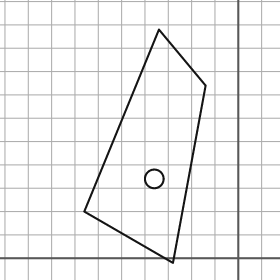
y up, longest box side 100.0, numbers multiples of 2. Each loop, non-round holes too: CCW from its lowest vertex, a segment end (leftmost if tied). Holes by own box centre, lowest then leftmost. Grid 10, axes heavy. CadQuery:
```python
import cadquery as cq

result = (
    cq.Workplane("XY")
    .moveTo(-28.0, -2.0)
    .lineTo(-14.0, 74.0)
    .lineTo(-34.0, 98.0)
    .lineTo(-66.0, 20.0)
    .close()
    .moveTo(-36.0, 34.0)
    .circle(4.0)
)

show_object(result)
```